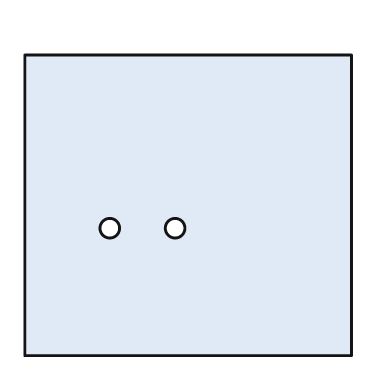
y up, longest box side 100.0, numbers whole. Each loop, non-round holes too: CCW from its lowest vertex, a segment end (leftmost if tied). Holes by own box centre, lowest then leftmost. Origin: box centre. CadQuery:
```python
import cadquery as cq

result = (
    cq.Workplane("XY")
    .moveTo(-50.0, -46.0)
    .lineTo(50.0, -46.0)
    .lineTo(50.0, 46.0)
    .lineTo(-50.0, 46.0)
    .close()
    .moveTo(-24.0, -7.0)
    .circle(3.0)
    .moveTo(-4.0, -7.0)
    .circle(3.0)
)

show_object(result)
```